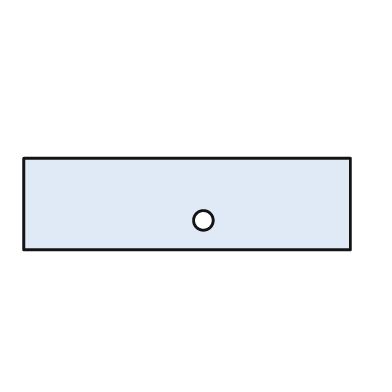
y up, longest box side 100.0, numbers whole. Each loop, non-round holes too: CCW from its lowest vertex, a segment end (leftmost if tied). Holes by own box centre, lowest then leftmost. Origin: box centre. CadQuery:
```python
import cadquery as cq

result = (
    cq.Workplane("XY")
    .moveTo(-50.0, -14.0)
    .lineTo(50.0, -14.0)
    .lineTo(50.0, 14.0)
    .lineTo(-50.0, 14.0)
    .close()
    .moveTo(5.0, -5.0)
    .circle(3.0)
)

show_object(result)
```